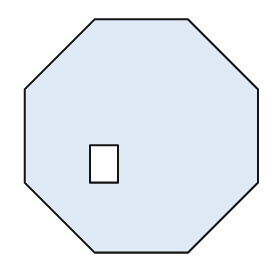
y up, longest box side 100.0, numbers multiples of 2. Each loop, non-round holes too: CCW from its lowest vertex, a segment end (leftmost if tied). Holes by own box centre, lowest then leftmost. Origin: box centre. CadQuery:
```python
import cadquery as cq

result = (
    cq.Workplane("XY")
    .moveTo(-20.0, -50.0)
    .lineTo(20.0, -50.0)
    .lineTo(50.0, -20.0)
    .lineTo(50.0, 20.0)
    .lineTo(20.0, 50.0)
    .lineTo(-20.0, 50.0)
    .lineTo(-50.0, 20.0)
    .lineTo(-50.0, -20.0)
    .close()
    .moveTo(-22.0, -20.0)
    .lineTo(-10.0, -20.0)
    .lineTo(-10.0, -4.0)
    .lineTo(-22.0, -4.0)
    .close()
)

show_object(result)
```